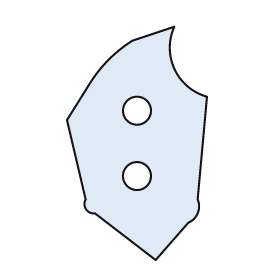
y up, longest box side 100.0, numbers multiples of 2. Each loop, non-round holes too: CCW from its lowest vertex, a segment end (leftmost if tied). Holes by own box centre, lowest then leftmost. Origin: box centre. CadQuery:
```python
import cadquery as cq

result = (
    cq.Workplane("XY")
    .moveTo(8.0, -50.0)
    .lineTo(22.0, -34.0)
    .threePointArc((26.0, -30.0), (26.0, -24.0))
    .lineTo(30.0, 20.0)
    .threePointArc((16.0, 32.0), (16.0, 50.0))
    .lineTo(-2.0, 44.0)
    .threePointArc((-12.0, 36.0), (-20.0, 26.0))
    .lineTo(-30.0, 10.0)
    .lineTo(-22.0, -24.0)
    .threePointArc((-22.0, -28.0), (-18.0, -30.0))
    .close()
    .moveTo(0.0, -14.0)
    .circle(6.0)
    .moveTo(0.0, 14.0)
    .circle(6.0)
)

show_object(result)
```